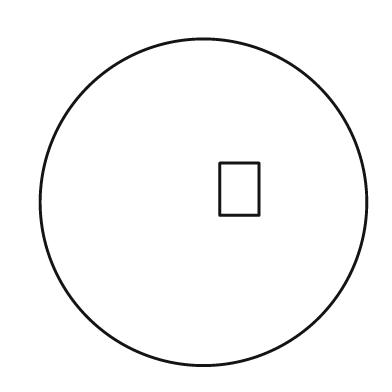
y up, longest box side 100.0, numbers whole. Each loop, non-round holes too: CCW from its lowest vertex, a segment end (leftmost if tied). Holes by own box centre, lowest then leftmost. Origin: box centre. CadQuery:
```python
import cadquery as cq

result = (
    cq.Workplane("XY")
    .moveTo(0.0, 0.0)
    .circle(50.0)
    .moveTo(5.0, -4.0)
    .lineTo(17.0, -4.0)
    .lineTo(17.0, 12.0)
    .lineTo(5.0, 12.0)
    .close()
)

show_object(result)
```